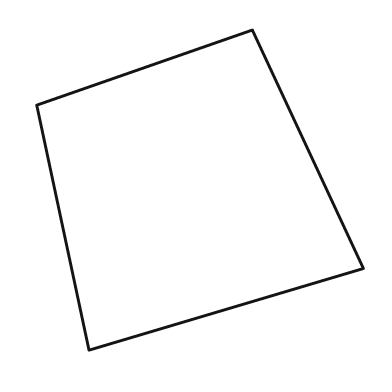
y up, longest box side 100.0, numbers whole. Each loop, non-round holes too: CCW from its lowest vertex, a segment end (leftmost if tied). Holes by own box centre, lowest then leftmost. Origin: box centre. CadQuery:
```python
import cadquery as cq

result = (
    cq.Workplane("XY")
    .moveTo(-34.0, -49.0)
    .lineTo(50.0, -24.0)
    .lineTo(16.0, 49.0)
    .lineTo(-50.0, 26.0)
    .close()
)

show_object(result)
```